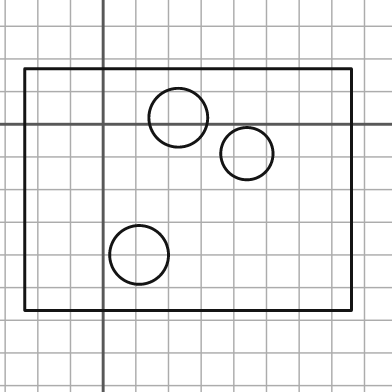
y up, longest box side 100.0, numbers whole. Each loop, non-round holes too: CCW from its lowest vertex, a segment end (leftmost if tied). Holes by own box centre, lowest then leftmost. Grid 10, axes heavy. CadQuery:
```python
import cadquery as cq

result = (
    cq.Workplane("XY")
    .moveTo(-24.0, -57.0)
    .lineTo(76.0, -57.0)
    .lineTo(76.0, 17.0)
    .lineTo(-24.0, 17.0)
    .close()
    .moveTo(11.0, -40.0)
    .circle(9.0)
    .moveTo(44.0, -9.0)
    .circle(8.0)
    .moveTo(23.0, 2.0)
    .circle(9.0)
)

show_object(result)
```